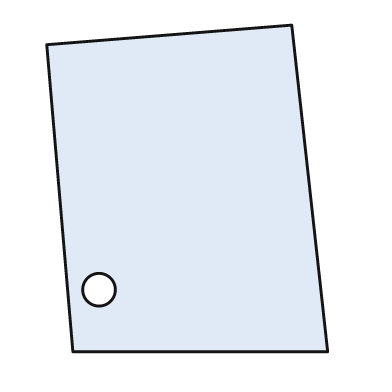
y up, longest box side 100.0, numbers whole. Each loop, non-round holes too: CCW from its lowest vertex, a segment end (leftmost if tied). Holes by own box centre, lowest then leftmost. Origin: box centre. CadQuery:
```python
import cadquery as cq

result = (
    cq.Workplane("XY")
    .moveTo(-35.0, -50.0)
    .lineTo(43.0, -50.0)
    .lineTo(32.0, 50.0)
    .lineTo(-43.0, 44.0)
    .close()
    .moveTo(-27.0, -31.0)
    .circle(5.0)
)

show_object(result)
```